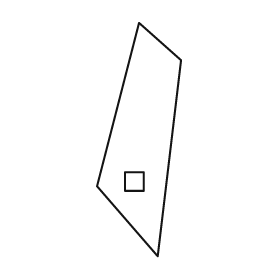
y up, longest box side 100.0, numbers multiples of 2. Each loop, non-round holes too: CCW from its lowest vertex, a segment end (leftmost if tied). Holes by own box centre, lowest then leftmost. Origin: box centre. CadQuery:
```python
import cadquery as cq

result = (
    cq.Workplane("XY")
    .moveTo(8.0, -50.0)
    .lineTo(18.0, 34.0)
    .lineTo(0.0, 50.0)
    .lineTo(-18.0, -20.0)
    .close()
    .moveTo(-6.0, -22.0)
    .lineTo(2.0, -22.0)
    .lineTo(2.0, -14.0)
    .lineTo(-6.0, -14.0)
    .close()
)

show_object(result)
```